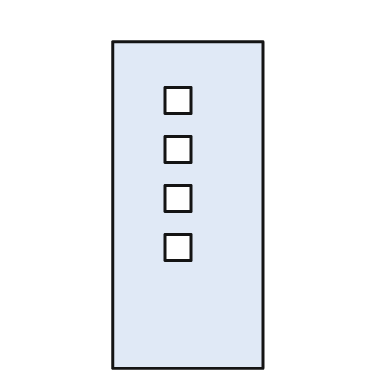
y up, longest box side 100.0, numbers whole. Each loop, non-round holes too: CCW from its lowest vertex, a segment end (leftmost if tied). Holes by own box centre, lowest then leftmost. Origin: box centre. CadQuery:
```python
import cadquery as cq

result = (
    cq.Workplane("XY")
    .moveTo(-23.0, -50.0)
    .lineTo(23.0, -50.0)
    .lineTo(23.0, 50.0)
    .lineTo(-23.0, 50.0)
    .close()
    .moveTo(-7.0, -17.0)
    .lineTo(1.0, -17.0)
    .lineTo(1.0, -9.0)
    .lineTo(-7.0, -9.0)
    .close()
    .moveTo(-7.0, -2.0)
    .lineTo(1.0, -2.0)
    .lineTo(1.0, 6.0)
    .lineTo(-7.0, 6.0)
    .close()
    .moveTo(-7.0, 13.0)
    .lineTo(1.0, 13.0)
    .lineTo(1.0, 21.0)
    .lineTo(-7.0, 21.0)
    .close()
    .moveTo(-7.0, 28.0)
    .lineTo(1.0, 28.0)
    .lineTo(1.0, 36.0)
    .lineTo(-7.0, 36.0)
    .close()
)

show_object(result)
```